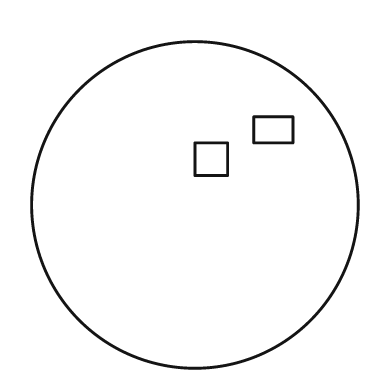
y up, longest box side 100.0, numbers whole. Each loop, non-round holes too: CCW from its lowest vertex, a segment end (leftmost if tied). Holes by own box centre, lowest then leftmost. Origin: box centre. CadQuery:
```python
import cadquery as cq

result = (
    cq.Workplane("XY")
    .moveTo(0.0, 0.0)
    .circle(50.0)
    .moveTo(0.0, 9.0)
    .lineTo(10.0, 9.0)
    .lineTo(10.0, 19.0)
    .lineTo(0.0, 19.0)
    .close()
    .moveTo(18.0, 19.0)
    .lineTo(30.0, 19.0)
    .lineTo(30.0, 27.0)
    .lineTo(18.0, 27.0)
    .close()
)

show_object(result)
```